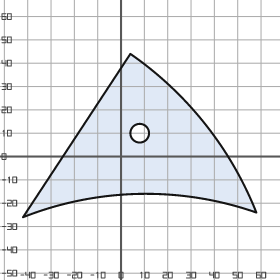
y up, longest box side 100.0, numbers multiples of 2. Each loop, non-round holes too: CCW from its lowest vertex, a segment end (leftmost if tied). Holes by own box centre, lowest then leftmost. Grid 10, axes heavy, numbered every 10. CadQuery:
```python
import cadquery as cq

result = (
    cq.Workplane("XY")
    .moveTo(-42.0, -26.0)
    .threePointArc((8.0, -16.0), (58.0, -24.0))
    .threePointArc((36.0, 14.0), (4.0, 44.0))
    .close()
    .moveTo(8.0, 10.0)
    .circle(4.0)
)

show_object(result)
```